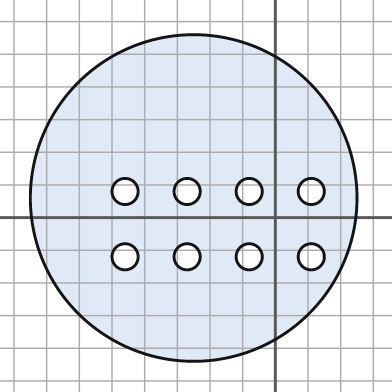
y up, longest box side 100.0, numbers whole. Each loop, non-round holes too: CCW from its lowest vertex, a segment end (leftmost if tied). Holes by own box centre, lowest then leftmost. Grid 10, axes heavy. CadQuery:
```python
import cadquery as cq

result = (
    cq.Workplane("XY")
    .moveTo(-25.0, 6.0)
    .circle(50.0)
    .moveTo(-46.0, -12.0)
    .circle(4.0)
    .moveTo(-27.0, -12.0)
    .circle(4.0)
    .moveTo(-8.0, -12.0)
    .circle(4.0)
    .moveTo(11.0, -12.0)
    .circle(4.0)
    .moveTo(-46.0, 8.0)
    .circle(4.0)
    .moveTo(-27.0, 8.0)
    .circle(4.0)
    .moveTo(-8.0, 8.0)
    .circle(4.0)
    .moveTo(11.0, 8.0)
    .circle(4.0)
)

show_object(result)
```